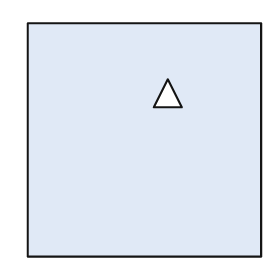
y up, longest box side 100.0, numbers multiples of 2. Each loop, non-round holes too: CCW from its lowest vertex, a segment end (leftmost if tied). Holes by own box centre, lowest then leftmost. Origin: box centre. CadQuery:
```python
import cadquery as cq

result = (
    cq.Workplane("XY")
    .moveTo(-50.0, -50.0)
    .lineTo(50.0, -50.0)
    .lineTo(50.0, 50.0)
    .lineTo(-50.0, 50.0)
    .close()
    .moveTo(4.0, 14.0)
    .lineTo(16.0, 14.0)
    .lineTo(10.0, 26.0)
    .close()
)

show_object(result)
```